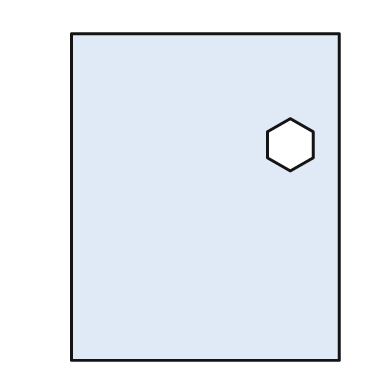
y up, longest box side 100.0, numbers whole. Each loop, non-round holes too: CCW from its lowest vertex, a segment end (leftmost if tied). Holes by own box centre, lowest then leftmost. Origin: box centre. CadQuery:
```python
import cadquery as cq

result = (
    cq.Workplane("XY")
    .moveTo(-41.0, -50.0)
    .lineTo(41.0, -50.0)
    .lineTo(41.0, 50.0)
    .lineTo(-41.0, 50.0)
    .close()
    .moveTo(26.0, 8.0)
    .lineTo(33.0, 12.0)
    .lineTo(33.0, 20.0)
    .lineTo(26.0, 24.0)
    .lineTo(19.0, 20.0)
    .lineTo(19.0, 12.0)
    .close()
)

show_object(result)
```